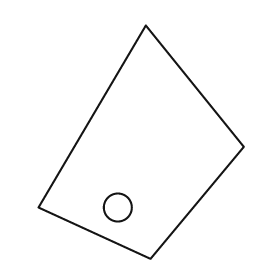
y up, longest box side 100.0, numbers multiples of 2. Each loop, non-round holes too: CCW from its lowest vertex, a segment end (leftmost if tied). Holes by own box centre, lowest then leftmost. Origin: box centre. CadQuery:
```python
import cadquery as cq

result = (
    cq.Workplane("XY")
    .moveTo(4.0, -50.0)
    .lineTo(44.0, -2.0)
    .lineTo(2.0, 50.0)
    .lineTo(-44.0, -28.0)
    .close()
    .moveTo(-10.0, -28.0)
    .circle(6.0)
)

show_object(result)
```